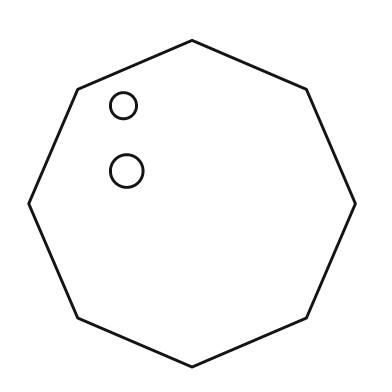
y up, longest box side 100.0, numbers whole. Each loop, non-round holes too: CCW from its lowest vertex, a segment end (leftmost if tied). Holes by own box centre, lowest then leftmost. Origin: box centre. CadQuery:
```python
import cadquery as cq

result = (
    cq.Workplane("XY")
    .moveTo(0.0, -50.0)
    .lineTo(35.0, -35.0)
    .lineTo(50.0, 0.0)
    .lineTo(35.0, 35.0)
    .lineTo(0.0, 50.0)
    .lineTo(-35.0, 35.0)
    .lineTo(-50.0, 0.0)
    .lineTo(-35.0, -35.0)
    .close()
    .moveTo(-20.0, 10.0)
    .circle(5.0)
    .moveTo(-21.0, 30.0)
    .circle(4.0)
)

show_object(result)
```